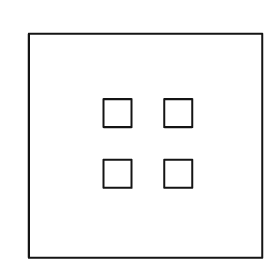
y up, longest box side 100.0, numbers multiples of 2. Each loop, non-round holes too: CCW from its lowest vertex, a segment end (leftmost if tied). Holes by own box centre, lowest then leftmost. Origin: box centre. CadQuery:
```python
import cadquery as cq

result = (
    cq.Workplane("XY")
    .moveTo(-50.0, -48.0)
    .lineTo(50.0, -48.0)
    .lineTo(50.0, 48.0)
    .lineTo(-50.0, 48.0)
    .close()
    .moveTo(-18.0, -18.0)
    .lineTo(-6.0, -18.0)
    .lineTo(-6.0, -6.0)
    .lineTo(-18.0, -6.0)
    .close()
    .moveTo(8.0, -18.0)
    .lineTo(20.0, -18.0)
    .lineTo(20.0, -6.0)
    .lineTo(8.0, -6.0)
    .close()
    .moveTo(-18.0, 8.0)
    .lineTo(-6.0, 8.0)
    .lineTo(-6.0, 20.0)
    .lineTo(-18.0, 20.0)
    .close()
    .moveTo(8.0, 8.0)
    .lineTo(20.0, 8.0)
    .lineTo(20.0, 20.0)
    .lineTo(8.0, 20.0)
    .close()
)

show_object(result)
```